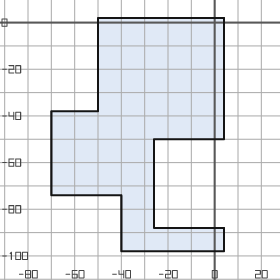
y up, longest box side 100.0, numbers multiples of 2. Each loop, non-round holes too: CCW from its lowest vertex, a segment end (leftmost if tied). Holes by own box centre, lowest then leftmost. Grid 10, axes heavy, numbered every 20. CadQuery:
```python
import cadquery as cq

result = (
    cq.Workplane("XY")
    .moveTo(-40.0, -98.0)
    .lineTo(4.0, -98.0)
    .lineTo(4.0, -88.0)
    .lineTo(-26.0, -88.0)
    .lineTo(-26.0, -50.0)
    .lineTo(4.0, -50.0)
    .lineTo(4.0, 2.0)
    .lineTo(-50.0, 2.0)
    .lineTo(-50.0, -38.0)
    .lineTo(-70.0, -38.0)
    .lineTo(-70.0, -74.0)
    .lineTo(-40.0, -74.0)
    .close()
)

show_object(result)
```